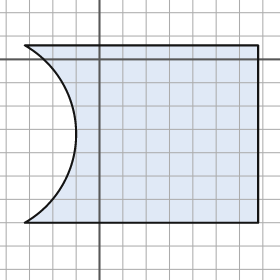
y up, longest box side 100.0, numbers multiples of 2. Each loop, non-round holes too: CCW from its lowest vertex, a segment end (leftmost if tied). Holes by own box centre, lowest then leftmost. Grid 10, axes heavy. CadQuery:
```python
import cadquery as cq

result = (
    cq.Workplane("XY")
    .moveTo(-32.0, -70.0)
    .lineTo(68.0, -70.0)
    .lineTo(68.0, 6.0)
    .lineTo(-32.0, 6.0)
    .threePointArc((-10.0, -32.0), (-32.0, -70.0))
    .close()
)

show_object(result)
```